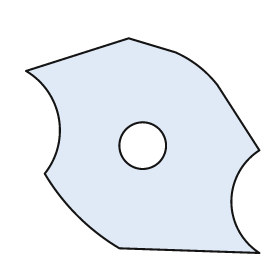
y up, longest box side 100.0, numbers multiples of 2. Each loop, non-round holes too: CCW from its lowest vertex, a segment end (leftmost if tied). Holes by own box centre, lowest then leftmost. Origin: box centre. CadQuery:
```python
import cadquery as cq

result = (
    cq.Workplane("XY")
    .moveTo(50.0, -46.0)
    .threePointArc((38.0, -24.0), (50.0, -2.0))
    .lineTo(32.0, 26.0)
    .threePointArc((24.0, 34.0), (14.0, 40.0))
    .lineTo(-6.0, 46.0)
    .lineTo(-50.0, 32.0)
    .threePointArc((-36.0, 12.0), (-42.0, -12.0))
    .threePointArc((-28.0, -30.0), (-10.0, -44.0))
    .close()
    .moveTo(0.0, 0.0)
    .circle(10.0)
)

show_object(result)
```